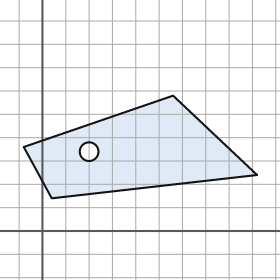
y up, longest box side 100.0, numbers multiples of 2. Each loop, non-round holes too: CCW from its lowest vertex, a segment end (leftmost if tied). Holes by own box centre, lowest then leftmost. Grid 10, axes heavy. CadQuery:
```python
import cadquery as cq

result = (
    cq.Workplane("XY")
    .moveTo(4.0, 14.0)
    .lineTo(92.0, 24.0)
    .lineTo(56.0, 58.0)
    .lineTo(-8.0, 36.0)
    .close()
    .moveTo(20.0, 34.0)
    .circle(4.0)
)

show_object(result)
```